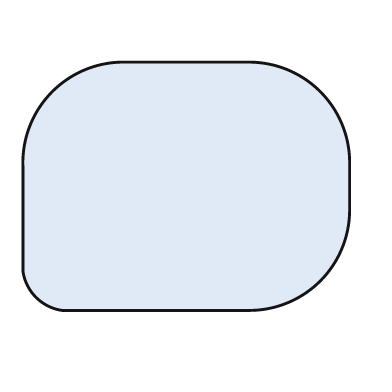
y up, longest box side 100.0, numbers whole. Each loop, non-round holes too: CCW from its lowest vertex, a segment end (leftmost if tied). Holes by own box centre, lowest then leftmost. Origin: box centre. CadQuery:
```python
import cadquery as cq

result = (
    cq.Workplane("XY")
    .moveTo(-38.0, -38.0)
    .lineTo(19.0, -38.0)
    .threePointArc((41.0, -29.0), (50.0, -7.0))
    .lineTo(50.0, 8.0)
    .threePointArc((41.0, 29.0), (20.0, 38.0))
    .lineTo(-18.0, 38.0)
    .threePointArc((-41.0, 29.0), (-50.0, 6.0))
    .lineTo(-50.0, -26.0)
    .threePointArc((-46.0, -34.0), (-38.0, -38.0))
    .close()
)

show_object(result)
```